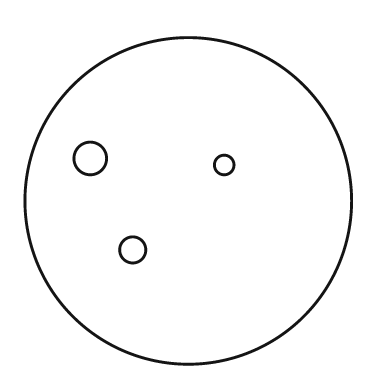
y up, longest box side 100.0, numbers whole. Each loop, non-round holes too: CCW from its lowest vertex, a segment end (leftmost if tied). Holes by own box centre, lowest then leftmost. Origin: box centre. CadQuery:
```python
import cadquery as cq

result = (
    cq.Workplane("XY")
    .moveTo(0.0, 0.0)
    .circle(50.0)
    .moveTo(-17.0, -15.0)
    .circle(4.0)
    .moveTo(11.0, 11.0)
    .circle(3.0)
    .moveTo(-30.0, 13.0)
    .circle(5.0)
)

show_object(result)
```